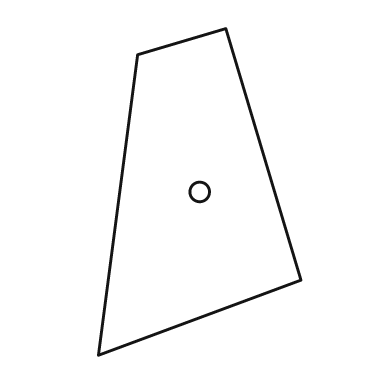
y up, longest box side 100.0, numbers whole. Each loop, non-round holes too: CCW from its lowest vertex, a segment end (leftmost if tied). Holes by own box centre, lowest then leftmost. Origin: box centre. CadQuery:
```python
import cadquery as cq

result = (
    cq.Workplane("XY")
    .moveTo(-31.0, -50.0)
    .lineTo(31.0, -27.0)
    .lineTo(8.0, 50.0)
    .lineTo(-19.0, 42.0)
    .close()
    .moveTo(0.0, 0.0)
    .circle(3.0)
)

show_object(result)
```